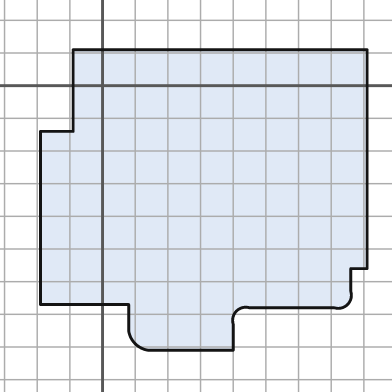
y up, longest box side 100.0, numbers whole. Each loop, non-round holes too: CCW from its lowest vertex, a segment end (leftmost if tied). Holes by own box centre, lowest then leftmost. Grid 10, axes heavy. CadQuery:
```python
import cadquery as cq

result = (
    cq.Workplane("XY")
    .moveTo(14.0, -81.0)
    .lineTo(40.0, -81.0)
    .lineTo(40.0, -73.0)
    .threePointArc((41.0, -69.0), (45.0, -68.0))
    .lineTo(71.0, -68.0)
    .threePointArc((75.0, -67.0), (76.0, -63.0))
    .lineTo(76.0, -56.0)
    .lineTo(81.0, -56.0)
    .lineTo(81.0, 11.0)
    .lineTo(-9.0, 11.0)
    .lineTo(-9.0, -14.0)
    .lineTo(-19.0, -14.0)
    .lineTo(-19.0, -67.0)
    .lineTo(8.0, -67.0)
    .lineTo(8.0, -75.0)
    .threePointArc((10.0, -79.0), (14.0, -81.0))
    .close()
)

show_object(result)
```